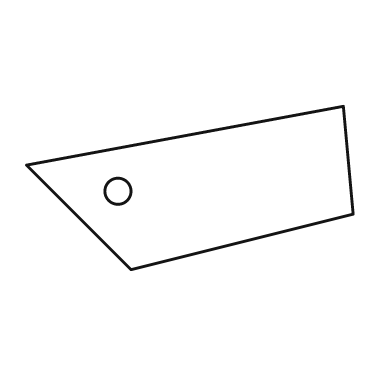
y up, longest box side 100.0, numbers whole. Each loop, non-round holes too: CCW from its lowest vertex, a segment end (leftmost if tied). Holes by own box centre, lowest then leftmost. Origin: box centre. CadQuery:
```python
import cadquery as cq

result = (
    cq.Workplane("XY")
    .moveTo(-18.0, -25.0)
    .lineTo(50.0, -8.0)
    .lineTo(47.0, 25.0)
    .lineTo(-50.0, 7.0)
    .close()
    .moveTo(-22.0, -1.0)
    .circle(4.0)
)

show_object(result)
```